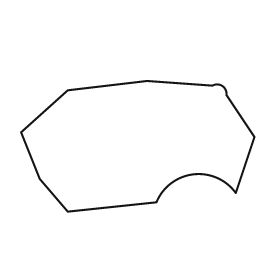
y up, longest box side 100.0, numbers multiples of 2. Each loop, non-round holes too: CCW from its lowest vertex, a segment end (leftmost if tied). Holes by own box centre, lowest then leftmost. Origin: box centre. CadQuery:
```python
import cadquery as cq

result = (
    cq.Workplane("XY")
    .moveTo(-30.0, -28.0)
    .lineTo(8.0, -24.0)
    .threePointArc((24.0, -12.0), (42.0, -20.0))
    .lineTo(50.0, 4.0)
    .lineTo(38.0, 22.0)
    .threePointArc((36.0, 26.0), (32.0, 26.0))
    .lineTo(4.0, 28.0)
    .lineTo(-30.0, 24.0)
    .lineTo(-50.0, 6.0)
    .lineTo(-42.0, -14.0)
    .close()
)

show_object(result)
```